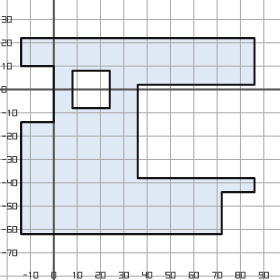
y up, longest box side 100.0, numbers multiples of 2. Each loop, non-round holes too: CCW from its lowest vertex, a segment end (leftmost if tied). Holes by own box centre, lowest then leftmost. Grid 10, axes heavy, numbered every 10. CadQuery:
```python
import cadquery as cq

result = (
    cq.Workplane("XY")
    .moveTo(-14.0, -62.0)
    .lineTo(72.0, -62.0)
    .lineTo(72.0, -44.0)
    .lineTo(86.0, -44.0)
    .lineTo(86.0, -38.0)
    .lineTo(36.0, -38.0)
    .lineTo(36.0, 2.0)
    .lineTo(86.0, 2.0)
    .lineTo(86.0, 22.0)
    .lineTo(-14.0, 22.0)
    .lineTo(-14.0, 10.0)
    .lineTo(0.0, 10.0)
    .lineTo(0.0, -14.0)
    .lineTo(-14.0, -14.0)
    .close()
    .moveTo(8.0, -8.0)
    .lineTo(24.0, -8.0)
    .lineTo(24.0, 8.0)
    .lineTo(8.0, 8.0)
    .close()
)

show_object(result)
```